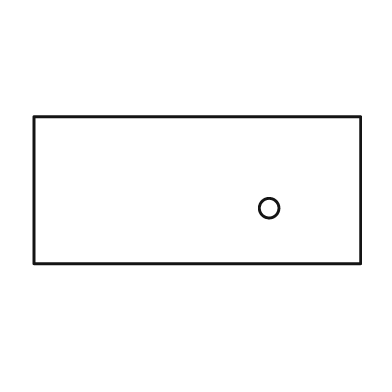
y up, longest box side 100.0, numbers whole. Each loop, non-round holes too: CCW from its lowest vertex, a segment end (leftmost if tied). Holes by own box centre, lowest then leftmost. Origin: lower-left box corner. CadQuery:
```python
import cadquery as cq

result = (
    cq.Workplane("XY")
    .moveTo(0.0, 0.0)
    .lineTo(100.0, 0.0)
    .lineTo(100.0, 45.0)
    .lineTo(0.0, 45.0)
    .close()
    .moveTo(72.0, 17.0)
    .circle(3.0)
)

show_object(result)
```